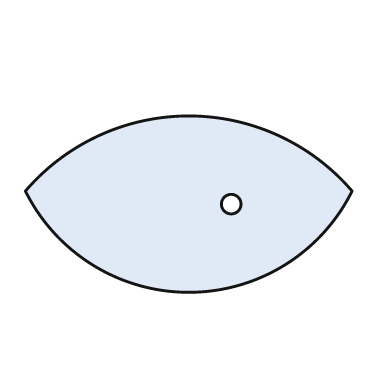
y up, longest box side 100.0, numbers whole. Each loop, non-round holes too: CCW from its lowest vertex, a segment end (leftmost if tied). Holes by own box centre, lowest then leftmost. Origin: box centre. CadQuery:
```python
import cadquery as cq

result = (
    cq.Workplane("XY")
    .moveTo(-50.0, 4.0)
    .threePointArc((0.0, -27.0), (50.0, 4.0))
    .threePointArc((0.0, 27.0), (-50.0, 4.0))
    .close()
    .moveTo(13.0, 0.0)
    .circle(3.0)
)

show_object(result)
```